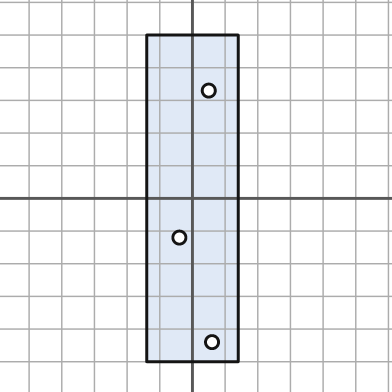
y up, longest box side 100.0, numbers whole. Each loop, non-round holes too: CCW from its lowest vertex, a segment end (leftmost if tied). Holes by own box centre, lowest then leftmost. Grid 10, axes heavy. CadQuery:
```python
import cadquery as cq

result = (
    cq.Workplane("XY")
    .moveTo(-14.0, -50.0)
    .lineTo(14.0, -50.0)
    .lineTo(14.0, 50.0)
    .lineTo(-14.0, 50.0)
    .close()
    .moveTo(6.0, -44.0)
    .circle(2.0)
    .moveTo(-4.0, -12.0)
    .circle(2.0)
    .moveTo(5.0, 33.0)
    .circle(2.0)
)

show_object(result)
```